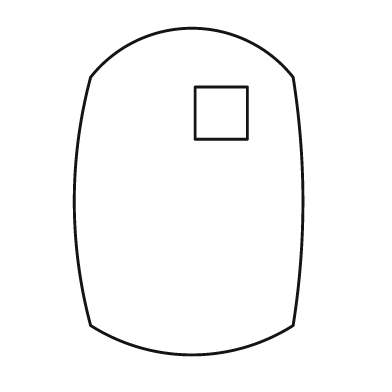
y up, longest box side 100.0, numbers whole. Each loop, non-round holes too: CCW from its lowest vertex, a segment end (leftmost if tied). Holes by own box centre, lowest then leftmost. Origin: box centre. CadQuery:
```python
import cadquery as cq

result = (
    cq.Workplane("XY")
    .moveTo(-30.0, -41.0)
    .threePointArc((1.0, -50.0), (32.0, -41.0))
    .threePointArc((35.0, -3.0), (32.0, 35.0))
    .threePointArc((1.0, 50.0), (-30.0, 35.0))
    .threePointArc((-35.0, -3.0), (-30.0, -41.0))
    .close()
    .moveTo(2.0, 16.0)
    .lineTo(18.0, 16.0)
    .lineTo(18.0, 32.0)
    .lineTo(2.0, 32.0)
    .close()
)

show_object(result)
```